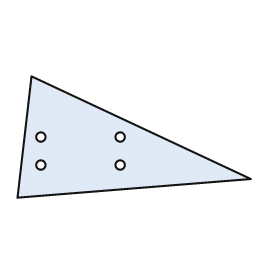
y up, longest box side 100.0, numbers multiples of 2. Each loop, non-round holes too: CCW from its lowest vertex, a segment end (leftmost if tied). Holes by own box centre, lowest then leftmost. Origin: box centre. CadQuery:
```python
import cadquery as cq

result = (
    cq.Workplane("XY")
    .moveTo(-50.0, -26.0)
    .lineTo(50.0, -18.0)
    .lineTo(-44.0, 26.0)
    .close()
    .moveTo(-40.0, -12.0)
    .circle(2.0)
    .moveTo(-6.0, -12.0)
    .circle(2.0)
    .moveTo(-40.0, 0.0)
    .circle(2.0)
    .moveTo(-6.0, 0.0)
    .circle(2.0)
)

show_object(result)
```